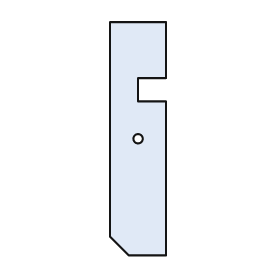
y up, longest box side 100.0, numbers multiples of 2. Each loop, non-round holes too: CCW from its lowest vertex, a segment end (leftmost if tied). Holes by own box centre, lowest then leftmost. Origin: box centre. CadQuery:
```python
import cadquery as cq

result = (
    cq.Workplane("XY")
    .moveTo(-4.0, -50.0)
    .lineTo(12.0, -50.0)
    .lineTo(12.0, 16.0)
    .lineTo(0.0, 16.0)
    .lineTo(0.0, 26.0)
    .lineTo(12.0, 26.0)
    .lineTo(12.0, 50.0)
    .lineTo(-12.0, 50.0)
    .lineTo(-12.0, -42.0)
    .close()
    .moveTo(0.0, 0.0)
    .circle(2.0)
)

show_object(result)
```